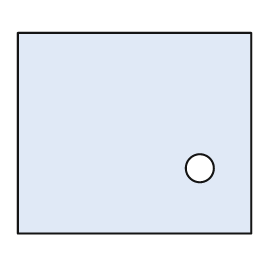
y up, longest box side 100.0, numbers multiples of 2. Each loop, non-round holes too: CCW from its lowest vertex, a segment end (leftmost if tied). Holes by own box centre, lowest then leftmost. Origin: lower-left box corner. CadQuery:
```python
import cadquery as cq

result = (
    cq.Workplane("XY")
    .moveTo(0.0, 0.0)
    .lineTo(100.0, 0.0)
    .lineTo(100.0, 86.0)
    .lineTo(0.0, 86.0)
    .close()
    .moveTo(78.0, 28.0)
    .circle(6.0)
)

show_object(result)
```